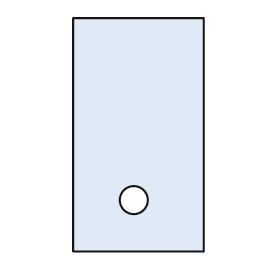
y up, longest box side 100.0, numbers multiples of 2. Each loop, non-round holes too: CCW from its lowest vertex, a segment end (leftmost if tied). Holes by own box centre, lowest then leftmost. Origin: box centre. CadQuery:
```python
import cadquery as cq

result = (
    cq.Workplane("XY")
    .moveTo(-28.0, -50.0)
    .lineTo(28.0, -50.0)
    .lineTo(28.0, 50.0)
    .lineTo(-28.0, 50.0)
    .close()
    .moveTo(-2.0, -28.0)
    .circle(6.0)
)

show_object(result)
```